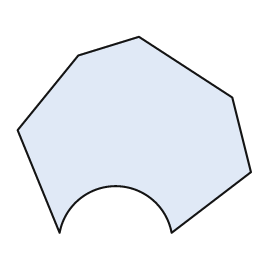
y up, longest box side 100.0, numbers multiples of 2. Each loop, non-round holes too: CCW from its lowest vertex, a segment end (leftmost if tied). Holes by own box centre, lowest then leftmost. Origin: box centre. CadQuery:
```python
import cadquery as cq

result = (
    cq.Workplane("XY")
    .moveTo(-32.0, -42.0)
    .threePointArc((-8.0, -22.0), (16.0, -42.0))
    .lineTo(50.0, -16.0)
    .lineTo(42.0, 16.0)
    .lineTo(2.0, 42.0)
    .lineTo(-24.0, 34.0)
    .lineTo(-50.0, 2.0)
    .close()
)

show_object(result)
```